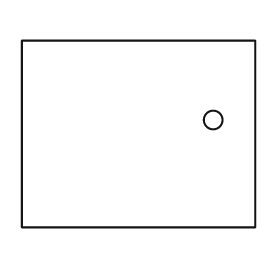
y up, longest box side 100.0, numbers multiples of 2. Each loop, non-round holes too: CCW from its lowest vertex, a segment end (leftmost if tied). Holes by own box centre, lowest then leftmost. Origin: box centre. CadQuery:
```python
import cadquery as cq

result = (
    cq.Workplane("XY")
    .moveTo(-50.0, -40.0)
    .lineTo(50.0, -40.0)
    .lineTo(50.0, 40.0)
    .lineTo(-50.0, 40.0)
    .close()
    .moveTo(32.0, 6.0)
    .circle(4.0)
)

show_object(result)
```